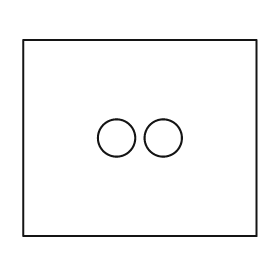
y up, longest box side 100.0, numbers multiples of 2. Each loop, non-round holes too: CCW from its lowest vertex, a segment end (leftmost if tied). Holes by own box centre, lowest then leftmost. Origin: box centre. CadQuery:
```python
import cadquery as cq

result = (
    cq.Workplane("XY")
    .moveTo(-50.0, -42.0)
    .lineTo(50.0, -42.0)
    .lineTo(50.0, 42.0)
    .lineTo(-50.0, 42.0)
    .close()
    .moveTo(-10.0, 0.0)
    .circle(8.0)
    .moveTo(10.0, 0.0)
    .circle(8.0)
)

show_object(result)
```